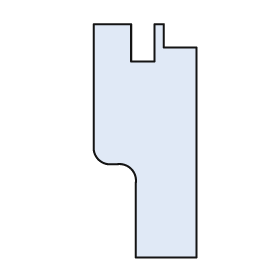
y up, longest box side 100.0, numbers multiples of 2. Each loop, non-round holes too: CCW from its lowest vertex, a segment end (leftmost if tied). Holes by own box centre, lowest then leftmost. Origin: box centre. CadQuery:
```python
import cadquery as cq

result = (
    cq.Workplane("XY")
    .moveTo(-4.0, -50.0)
    .lineTo(22.0, -50.0)
    .lineTo(22.0, 40.0)
    .lineTo(8.0, 40.0)
    .lineTo(8.0, 50.0)
    .lineTo(4.0, 50.0)
    .lineTo(4.0, 34.0)
    .lineTo(-6.0, 34.0)
    .lineTo(-6.0, 50.0)
    .lineTo(-22.0, 50.0)
    .lineTo(-22.0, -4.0)
    .threePointArc((-20.0, -8.0), (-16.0, -10.0))
    .lineTo(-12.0, -10.0)
    .threePointArc((-6.0, -12.0), (-4.0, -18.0))
    .close()
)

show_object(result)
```